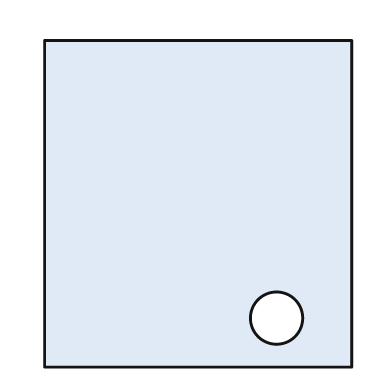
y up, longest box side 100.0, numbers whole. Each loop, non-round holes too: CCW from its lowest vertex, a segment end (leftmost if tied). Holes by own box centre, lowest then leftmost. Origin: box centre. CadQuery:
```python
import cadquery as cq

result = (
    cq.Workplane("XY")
    .moveTo(-47.0, -50.0)
    .lineTo(47.0, -50.0)
    .lineTo(47.0, 50.0)
    .lineTo(-47.0, 50.0)
    .close()
    .moveTo(24.0, -35.0)
    .circle(8.0)
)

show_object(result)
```